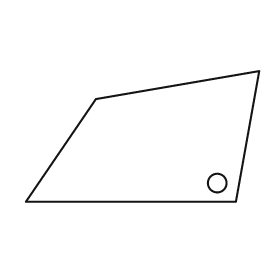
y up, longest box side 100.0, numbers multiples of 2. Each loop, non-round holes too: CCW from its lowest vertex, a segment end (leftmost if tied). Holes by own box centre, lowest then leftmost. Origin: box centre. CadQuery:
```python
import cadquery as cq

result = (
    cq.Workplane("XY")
    .moveTo(-50.0, -28.0)
    .lineTo(40.0, -28.0)
    .lineTo(50.0, 28.0)
    .lineTo(-20.0, 16.0)
    .close()
    .moveTo(32.0, -20.0)
    .circle(4.0)
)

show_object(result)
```